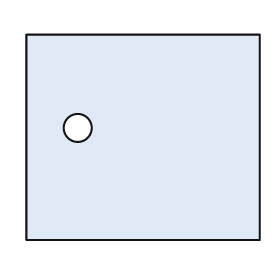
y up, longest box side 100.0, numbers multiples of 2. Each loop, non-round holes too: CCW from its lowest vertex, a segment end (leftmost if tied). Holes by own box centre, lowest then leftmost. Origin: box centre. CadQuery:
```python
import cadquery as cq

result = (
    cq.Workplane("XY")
    .moveTo(-50.0, -44.0)
    .lineTo(50.0, -44.0)
    .lineTo(50.0, 44.0)
    .lineTo(-50.0, 44.0)
    .close()
    .moveTo(-28.0, 4.0)
    .circle(6.0)
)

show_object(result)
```